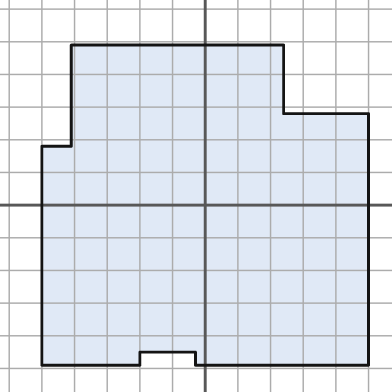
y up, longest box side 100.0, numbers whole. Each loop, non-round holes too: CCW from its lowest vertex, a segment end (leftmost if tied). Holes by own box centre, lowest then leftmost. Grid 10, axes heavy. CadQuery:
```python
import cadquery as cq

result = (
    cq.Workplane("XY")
    .moveTo(-50.0, -49.0)
    .lineTo(-20.0, -49.0)
    .lineTo(-20.0, -45.0)
    .lineTo(-3.0, -45.0)
    .lineTo(-3.0, -49.0)
    .lineTo(50.0, -49.0)
    .lineTo(50.0, 28.0)
    .lineTo(24.0, 28.0)
    .lineTo(24.0, 49.0)
    .lineTo(-41.0, 49.0)
    .lineTo(-41.0, 18.0)
    .lineTo(-50.0, 18.0)
    .close()
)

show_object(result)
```